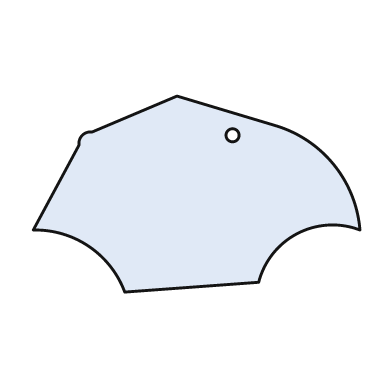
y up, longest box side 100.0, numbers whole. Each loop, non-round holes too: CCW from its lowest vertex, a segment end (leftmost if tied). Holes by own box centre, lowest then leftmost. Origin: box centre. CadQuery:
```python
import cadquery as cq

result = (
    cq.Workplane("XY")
    .moveTo(-22.0, -30.0)
    .lineTo(19.0, -27.0)
    .threePointArc((31.0, -12.0), (50.0, -11.0))
    .threePointArc((42.0, 9.0), (24.0, 21.0))
    .lineTo(-6.0, 30.0)
    .lineTo(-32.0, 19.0)
    .threePointArc((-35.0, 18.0), (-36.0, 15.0))
    .lineTo(-50.0, -11.0)
    .threePointArc((-33.0, -16.0), (-22.0, -30.0))
    .close()
    .moveTo(11.0, 18.0)
    .circle(2.0)
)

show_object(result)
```